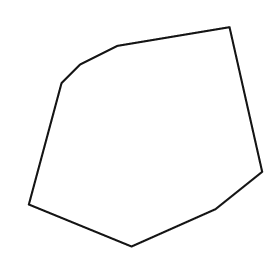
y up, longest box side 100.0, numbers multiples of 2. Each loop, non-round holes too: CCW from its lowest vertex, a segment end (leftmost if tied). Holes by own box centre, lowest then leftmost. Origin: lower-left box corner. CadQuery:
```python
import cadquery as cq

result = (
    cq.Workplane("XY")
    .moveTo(44.0, 0.0)
    .lineTo(80.0, 16.0)
    .lineTo(100.0, 32.0)
    .lineTo(86.0, 94.0)
    .lineTo(38.0, 86.0)
    .lineTo(22.0, 78.0)
    .lineTo(14.0, 70.0)
    .lineTo(0.0, 18.0)
    .close()
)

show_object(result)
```